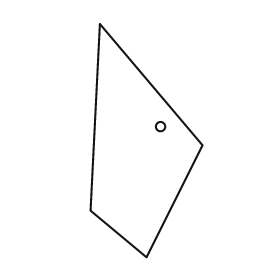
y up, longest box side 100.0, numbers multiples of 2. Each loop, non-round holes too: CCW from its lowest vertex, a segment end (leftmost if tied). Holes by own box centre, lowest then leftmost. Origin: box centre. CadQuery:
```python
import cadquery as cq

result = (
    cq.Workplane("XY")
    .moveTo(0.0, -50.0)
    .lineTo(24.0, -2.0)
    .lineTo(-20.0, 50.0)
    .lineTo(-24.0, -30.0)
    .close()
    .moveTo(6.0, 6.0)
    .circle(2.0)
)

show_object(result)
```